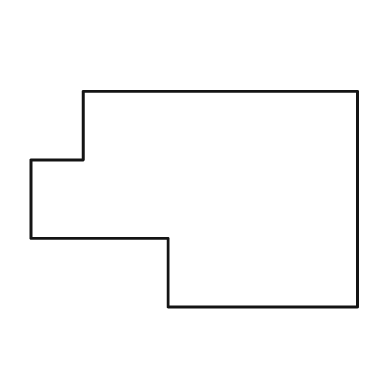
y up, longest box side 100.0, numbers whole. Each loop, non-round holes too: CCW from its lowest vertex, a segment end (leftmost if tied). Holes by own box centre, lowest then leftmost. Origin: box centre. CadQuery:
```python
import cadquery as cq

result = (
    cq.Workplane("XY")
    .moveTo(-8.0, -33.0)
    .lineTo(50.0, -33.0)
    .lineTo(50.0, 33.0)
    .lineTo(-34.0, 33.0)
    .lineTo(-34.0, 12.0)
    .lineTo(-50.0, 12.0)
    .lineTo(-50.0, -12.0)
    .lineTo(-8.0, -12.0)
    .close()
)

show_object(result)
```